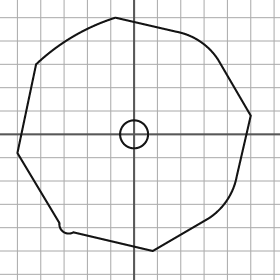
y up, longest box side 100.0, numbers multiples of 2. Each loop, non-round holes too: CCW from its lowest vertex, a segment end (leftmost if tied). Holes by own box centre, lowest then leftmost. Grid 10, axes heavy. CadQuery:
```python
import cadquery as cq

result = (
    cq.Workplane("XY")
    .moveTo(8.0, -50.0)
    .lineTo(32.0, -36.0)
    .threePointArc((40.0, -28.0), (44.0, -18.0))
    .lineTo(50.0, 8.0)
    .lineTo(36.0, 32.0)
    .threePointArc((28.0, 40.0), (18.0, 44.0))
    .lineTo(-8.0, 50.0)
    .threePointArc((-26.0, 42.0), (-42.0, 30.0))
    .lineTo(-50.0, -8.0)
    .lineTo(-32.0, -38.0)
    .threePointArc((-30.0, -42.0), (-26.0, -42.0))
    .close()
    .moveTo(0.0, 0.0)
    .circle(6.0)
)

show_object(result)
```